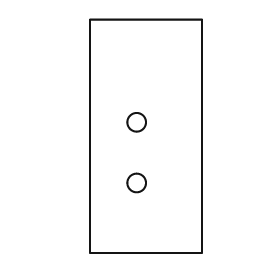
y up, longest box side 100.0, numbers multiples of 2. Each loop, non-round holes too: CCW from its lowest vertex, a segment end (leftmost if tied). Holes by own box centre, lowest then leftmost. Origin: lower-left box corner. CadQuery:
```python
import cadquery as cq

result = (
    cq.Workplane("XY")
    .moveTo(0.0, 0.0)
    .lineTo(48.0, 0.0)
    .lineTo(48.0, 100.0)
    .lineTo(0.0, 100.0)
    .close()
    .moveTo(20.0, 30.0)
    .circle(4.0)
    .moveTo(20.0, 56.0)
    .circle(4.0)
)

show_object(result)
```